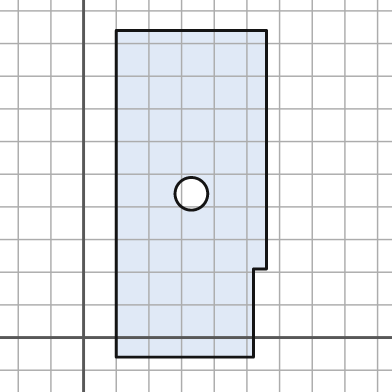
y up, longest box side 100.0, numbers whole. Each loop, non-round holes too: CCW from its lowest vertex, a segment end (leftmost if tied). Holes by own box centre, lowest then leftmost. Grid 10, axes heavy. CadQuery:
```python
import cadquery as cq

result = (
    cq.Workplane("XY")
    .moveTo(10.0, -6.0)
    .lineTo(52.0, -6.0)
    .lineTo(52.0, 21.0)
    .lineTo(56.0, 21.0)
    .lineTo(56.0, 94.0)
    .lineTo(10.0, 94.0)
    .close()
    .moveTo(33.0, 44.0)
    .circle(5.0)
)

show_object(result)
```